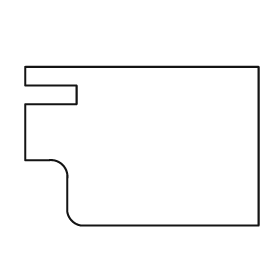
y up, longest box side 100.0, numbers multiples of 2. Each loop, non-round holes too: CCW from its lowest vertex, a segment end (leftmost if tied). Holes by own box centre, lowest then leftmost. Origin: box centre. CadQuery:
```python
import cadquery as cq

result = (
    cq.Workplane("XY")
    .moveTo(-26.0, -34.0)
    .lineTo(50.0, -34.0)
    .lineTo(50.0, 34.0)
    .lineTo(-50.0, 34.0)
    .lineTo(-50.0, 26.0)
    .lineTo(-28.0, 26.0)
    .lineTo(-28.0, 18.0)
    .lineTo(-50.0, 18.0)
    .lineTo(-50.0, -6.0)
    .lineTo(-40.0, -6.0)
    .threePointArc((-34.0, -8.0), (-32.0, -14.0))
    .lineTo(-32.0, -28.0)
    .threePointArc((-30.0, -32.0), (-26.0, -34.0))
    .close()
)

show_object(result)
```